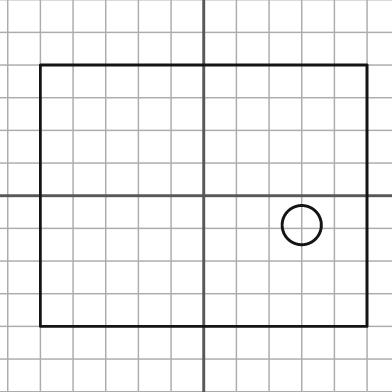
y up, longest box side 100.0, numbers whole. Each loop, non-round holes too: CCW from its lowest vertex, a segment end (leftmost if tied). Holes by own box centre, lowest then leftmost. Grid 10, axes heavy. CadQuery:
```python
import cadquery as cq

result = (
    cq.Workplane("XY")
    .moveTo(-50.0, -40.0)
    .lineTo(50.0, -40.0)
    .lineTo(50.0, 40.0)
    .lineTo(-50.0, 40.0)
    .close()
    .moveTo(30.0, -9.0)
    .circle(6.0)
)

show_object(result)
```